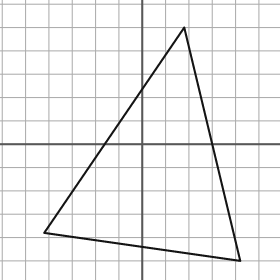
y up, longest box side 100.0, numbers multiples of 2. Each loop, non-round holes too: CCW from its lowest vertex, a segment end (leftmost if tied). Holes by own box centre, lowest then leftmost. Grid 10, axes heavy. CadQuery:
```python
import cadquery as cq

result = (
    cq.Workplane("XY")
    .moveTo(42.0, -50.0)
    .lineTo(18.0, 50.0)
    .lineTo(-42.0, -38.0)
    .close()
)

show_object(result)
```